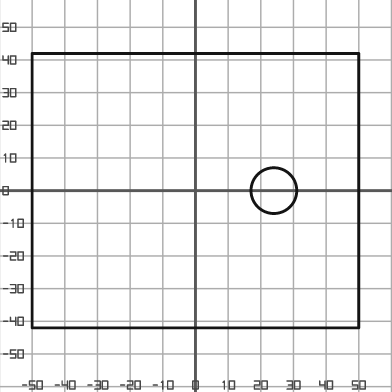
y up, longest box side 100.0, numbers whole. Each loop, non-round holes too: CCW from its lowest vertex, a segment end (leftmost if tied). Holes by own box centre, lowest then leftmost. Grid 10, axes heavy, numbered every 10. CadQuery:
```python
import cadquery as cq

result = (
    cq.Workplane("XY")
    .moveTo(-50.0, -42.0)
    .lineTo(50.0, -42.0)
    .lineTo(50.0, 42.0)
    .lineTo(-50.0, 42.0)
    .close()
    .moveTo(24.0, 0.0)
    .circle(7.0)
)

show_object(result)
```